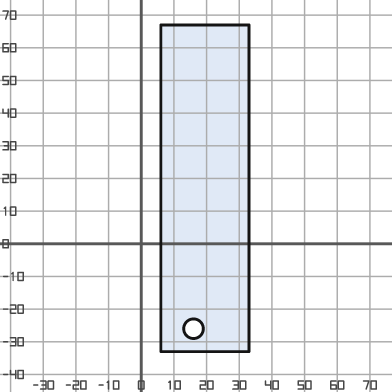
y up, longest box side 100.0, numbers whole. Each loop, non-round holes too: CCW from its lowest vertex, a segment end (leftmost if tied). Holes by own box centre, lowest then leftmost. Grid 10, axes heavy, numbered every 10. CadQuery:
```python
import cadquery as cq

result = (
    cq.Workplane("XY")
    .moveTo(6.0, -33.0)
    .lineTo(33.0, -33.0)
    .lineTo(33.0, 67.0)
    .lineTo(6.0, 67.0)
    .close()
    .moveTo(16.0, -26.0)
    .circle(3.0)
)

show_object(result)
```